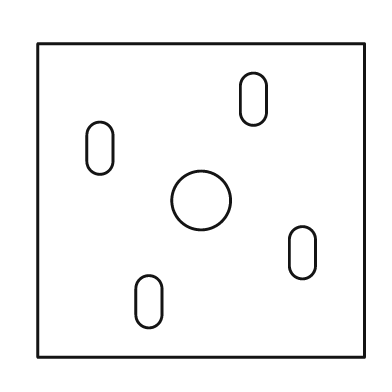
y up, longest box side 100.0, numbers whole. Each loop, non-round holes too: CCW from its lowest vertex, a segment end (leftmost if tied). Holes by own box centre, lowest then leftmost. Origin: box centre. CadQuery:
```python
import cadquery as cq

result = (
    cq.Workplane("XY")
    .moveTo(-50.0, -48.0)
    .lineTo(50.0, -48.0)
    .lineTo(50.0, 48.0)
    .lineTo(-50.0, 48.0)
    .close()
    .moveTo(-20.0, -35.0)
    .threePointArc((-16.0, -39.0), (-12.0, -35.0))
    .lineTo(-12.0, -27.0)
    .threePointArc((-16.0, -23.0), (-20.0, -27.0))
    .close()
    .moveTo(27.0, -20.0)
    .threePointArc((31.0, -24.0), (35.0, -20.0))
    .lineTo(35.0, -12.0)
    .threePointArc((31.0, -8.0), (27.0, -12.0))
    .close()
    .moveTo(0.0, 0.0)
    .circle(9.0)
    .moveTo(-35.0, 12.0)
    .threePointArc((-31.0, 8.0), (-27.0, 12.0))
    .lineTo(-27.0, 20.0)
    .threePointArc((-31.0, 24.0), (-35.0, 20.0))
    .close()
    .moveTo(12.0, 27.0)
    .threePointArc((16.0, 23.0), (20.0, 27.0))
    .lineTo(20.0, 35.0)
    .threePointArc((16.0, 39.0), (12.0, 35.0))
    .close()
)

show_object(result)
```